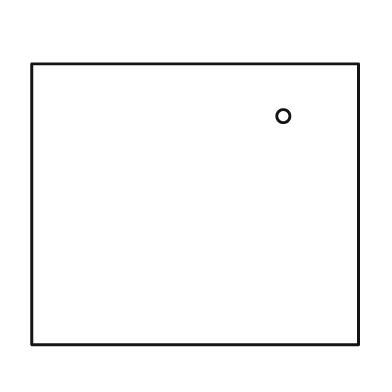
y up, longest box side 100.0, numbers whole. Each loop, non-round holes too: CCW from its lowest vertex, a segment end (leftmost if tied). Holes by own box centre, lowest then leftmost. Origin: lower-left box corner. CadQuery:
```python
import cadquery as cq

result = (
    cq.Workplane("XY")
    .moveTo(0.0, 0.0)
    .lineTo(100.0, 0.0)
    .lineTo(100.0, 86.0)
    .lineTo(0.0, 86.0)
    .close()
    .moveTo(77.0, 70.0)
    .circle(2.0)
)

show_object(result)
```